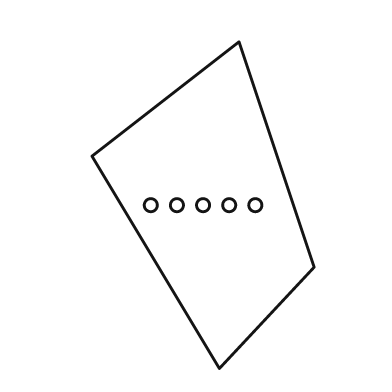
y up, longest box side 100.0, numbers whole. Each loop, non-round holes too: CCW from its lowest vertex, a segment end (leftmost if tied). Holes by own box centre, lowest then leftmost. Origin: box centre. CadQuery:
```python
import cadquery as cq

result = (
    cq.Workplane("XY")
    .moveTo(5.0, -50.0)
    .lineTo(34.0, -19.0)
    .lineTo(11.0, 50.0)
    .lineTo(-34.0, 15.0)
    .close()
    .moveTo(-16.0, 0.0)
    .circle(2.0)
    .moveTo(-8.0, 0.0)
    .circle(2.0)
    .moveTo(0.0, 0.0)
    .circle(2.0)
    .moveTo(8.0, 0.0)
    .circle(2.0)
    .moveTo(16.0, 0.0)
    .circle(2.0)
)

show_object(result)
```